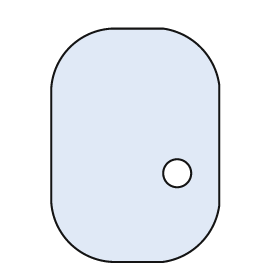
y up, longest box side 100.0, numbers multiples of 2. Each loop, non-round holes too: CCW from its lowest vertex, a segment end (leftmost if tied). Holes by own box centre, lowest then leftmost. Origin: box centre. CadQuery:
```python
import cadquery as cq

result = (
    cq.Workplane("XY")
    .moveTo(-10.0, -50.0)
    .lineTo(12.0, -50.0)
    .threePointArc((28.0, -42.0), (36.0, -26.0))
    .lineTo(36.0, 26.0)
    .threePointArc((28.0, 42.0), (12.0, 50.0))
    .lineTo(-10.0, 50.0)
    .threePointArc((-28.0, 42.0), (-36.0, 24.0))
    .lineTo(-36.0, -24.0)
    .threePointArc((-28.0, -42.0), (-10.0, -50.0))
    .close()
    .moveTo(18.0, -12.0)
    .circle(6.0)
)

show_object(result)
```